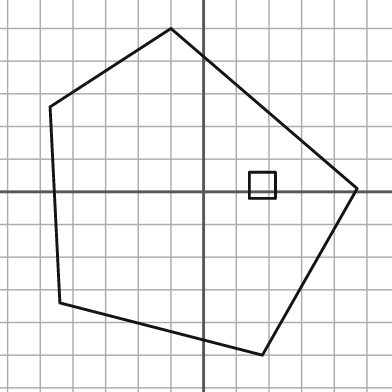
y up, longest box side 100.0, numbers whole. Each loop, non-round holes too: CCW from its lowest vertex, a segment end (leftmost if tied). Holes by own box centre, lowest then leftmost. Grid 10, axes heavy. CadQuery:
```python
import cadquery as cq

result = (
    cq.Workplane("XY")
    .moveTo(18.0, -50.0)
    .lineTo(47.0, 1.0)
    .lineTo(-10.0, 50.0)
    .lineTo(-47.0, 26.0)
    .lineTo(-44.0, -34.0)
    .close()
    .moveTo(14.0, -2.0)
    .lineTo(22.0, -2.0)
    .lineTo(22.0, 6.0)
    .lineTo(14.0, 6.0)
    .close()
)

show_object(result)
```